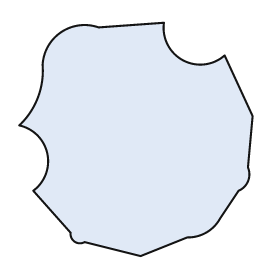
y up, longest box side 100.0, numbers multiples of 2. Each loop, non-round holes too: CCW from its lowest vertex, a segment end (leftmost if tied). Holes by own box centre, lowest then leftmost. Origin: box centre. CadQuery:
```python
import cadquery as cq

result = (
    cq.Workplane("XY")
    .moveTo(2.0, -50.0)
    .lineTo(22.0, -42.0)
    .threePointArc((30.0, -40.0), (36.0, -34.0))
    .lineTo(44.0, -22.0)
    .threePointArc((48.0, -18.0), (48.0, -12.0))
    .lineTo(50.0, 10.0)
    .lineTo(38.0, 36.0)
    .threePointArc((20.0, 34.0), (12.0, 50.0))
    .lineTo(-16.0, 48.0)
    .threePointArc((-32.0, 46.0), (-40.0, 32.0))
    .threePointArc((-42.0, 18.0), (-50.0, 6.0))
    .threePointArc((-38.0, -6.0), (-44.0, -22.0))
    .lineTo(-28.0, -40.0)
    .threePointArc((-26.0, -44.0), (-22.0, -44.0))
    .close()
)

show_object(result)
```